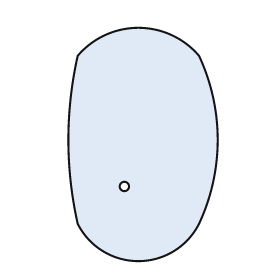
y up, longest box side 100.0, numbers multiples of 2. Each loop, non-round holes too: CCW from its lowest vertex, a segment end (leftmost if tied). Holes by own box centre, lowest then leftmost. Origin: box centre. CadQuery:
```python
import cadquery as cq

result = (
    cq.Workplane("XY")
    .moveTo(-28.0, -34.0)
    .threePointArc((-2.0, -50.0), (24.0, -34.0))
    .threePointArc((32.0, 2.0), (24.0, 38.0))
    .threePointArc((-2.0, 50.0), (-28.0, 38.0))
    .threePointArc((-32.0, 2.0), (-28.0, -34.0))
    .close()
    .moveTo(-8.0, -18.0)
    .circle(2.0)
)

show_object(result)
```